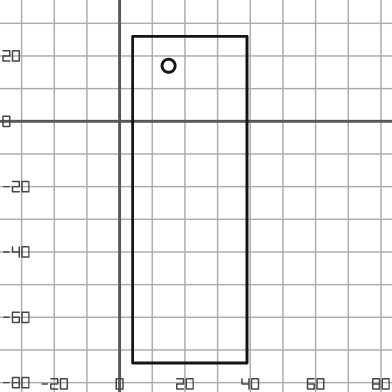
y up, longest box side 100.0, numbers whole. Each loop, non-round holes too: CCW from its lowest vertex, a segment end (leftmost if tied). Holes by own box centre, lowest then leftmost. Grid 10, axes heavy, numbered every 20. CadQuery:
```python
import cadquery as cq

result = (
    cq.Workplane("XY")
    .moveTo(4.0, -74.0)
    .lineTo(39.0, -74.0)
    .lineTo(39.0, 26.0)
    .lineTo(4.0, 26.0)
    .close()
    .moveTo(15.0, 17.0)
    .circle(2.0)
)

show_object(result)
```